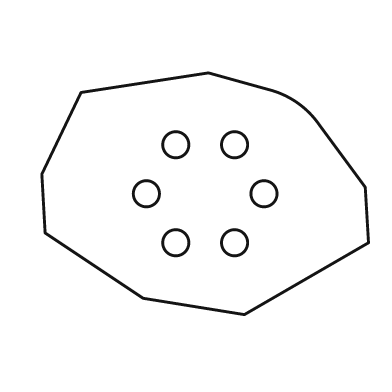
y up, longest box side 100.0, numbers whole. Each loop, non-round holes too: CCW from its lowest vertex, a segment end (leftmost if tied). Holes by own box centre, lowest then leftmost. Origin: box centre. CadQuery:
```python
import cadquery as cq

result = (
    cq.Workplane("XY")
    .moveTo(12.0, -37.0)
    .lineTo(50.0, -15.0)
    .lineTo(49.0, 2.0)
    .lineTo(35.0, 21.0)
    .threePointArc((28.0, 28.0), (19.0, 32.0))
    .lineTo(1.0, 37.0)
    .lineTo(-38.0, 31.0)
    .lineTo(-50.0, 6.0)
    .lineTo(-49.0, -12.0)
    .lineTo(-19.0, -32.0)
    .close()
    .moveTo(-9.0, -15.0)
    .circle(4.0)
    .moveTo(9.0, -15.0)
    .circle(4.0)
    .moveTo(-18.0, 0.0)
    .circle(4.0)
    .moveTo(18.0, 0.0)
    .circle(4.0)
    .moveTo(-9.0, 15.0)
    .circle(4.0)
    .moveTo(9.0, 15.0)
    .circle(4.0)
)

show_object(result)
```